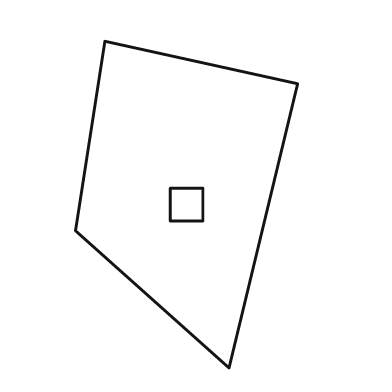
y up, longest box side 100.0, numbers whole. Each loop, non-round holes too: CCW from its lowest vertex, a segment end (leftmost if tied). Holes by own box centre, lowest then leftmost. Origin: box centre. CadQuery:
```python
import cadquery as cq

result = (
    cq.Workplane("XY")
    .moveTo(13.0, -50.0)
    .lineTo(34.0, 37.0)
    .lineTo(-25.0, 50.0)
    .lineTo(-34.0, -8.0)
    .close()
    .moveTo(-5.0, -5.0)
    .lineTo(5.0, -5.0)
    .lineTo(5.0, 5.0)
    .lineTo(-5.0, 5.0)
    .close()
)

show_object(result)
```